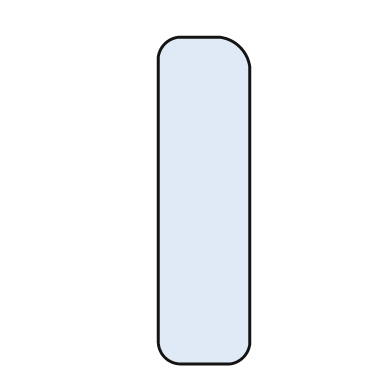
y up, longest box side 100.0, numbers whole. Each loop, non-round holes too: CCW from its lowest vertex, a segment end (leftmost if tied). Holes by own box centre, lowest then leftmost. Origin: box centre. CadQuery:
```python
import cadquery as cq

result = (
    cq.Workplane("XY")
    .moveTo(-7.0, -50.0)
    .lineTo(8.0, -50.0)
    .threePointArc((12.0, -48.0), (14.0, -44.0))
    .lineTo(14.0, 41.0)
    .threePointArc((11.0, 47.0), (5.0, 50.0))
    .lineTo(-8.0, 50.0)
    .threePointArc((-12.0, 48.0), (-14.0, 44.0))
    .lineTo(-14.0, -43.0)
    .threePointArc((-12.0, -48.0), (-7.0, -50.0))
    .close()
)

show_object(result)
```